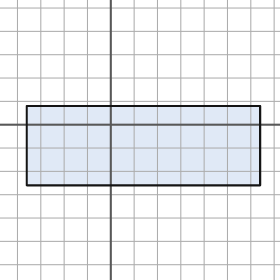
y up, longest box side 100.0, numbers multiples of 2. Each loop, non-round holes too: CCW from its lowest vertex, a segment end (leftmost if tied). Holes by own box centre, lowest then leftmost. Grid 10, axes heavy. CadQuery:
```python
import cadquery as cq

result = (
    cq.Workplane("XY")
    .moveTo(-36.0, -26.0)
    .lineTo(64.0, -26.0)
    .lineTo(64.0, 8.0)
    .lineTo(-36.0, 8.0)
    .close()
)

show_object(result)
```